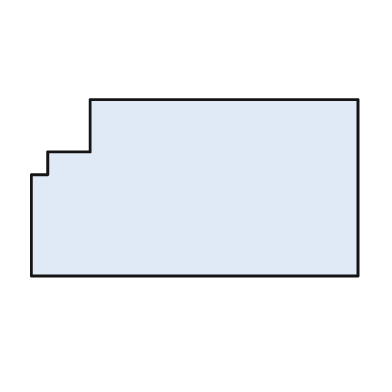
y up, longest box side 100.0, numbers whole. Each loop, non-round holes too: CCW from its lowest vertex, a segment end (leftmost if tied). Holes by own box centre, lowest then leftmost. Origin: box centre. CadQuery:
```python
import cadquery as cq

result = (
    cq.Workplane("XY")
    .moveTo(-50.0, -27.0)
    .lineTo(50.0, -27.0)
    .lineTo(50.0, 27.0)
    .lineTo(-32.0, 27.0)
    .lineTo(-32.0, 11.0)
    .lineTo(-45.0, 11.0)
    .lineTo(-45.0, 4.0)
    .lineTo(-50.0, 4.0)
    .close()
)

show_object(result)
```